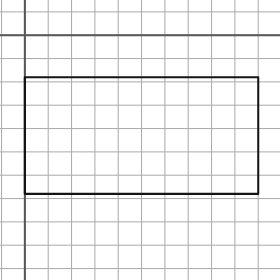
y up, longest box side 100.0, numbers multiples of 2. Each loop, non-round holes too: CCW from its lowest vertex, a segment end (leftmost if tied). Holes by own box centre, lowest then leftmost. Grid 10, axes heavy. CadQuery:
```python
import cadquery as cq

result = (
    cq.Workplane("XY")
    .moveTo(0.0, -68.0)
    .lineTo(100.0, -68.0)
    .lineTo(100.0, -18.0)
    .lineTo(0.0, -18.0)
    .close()
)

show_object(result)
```